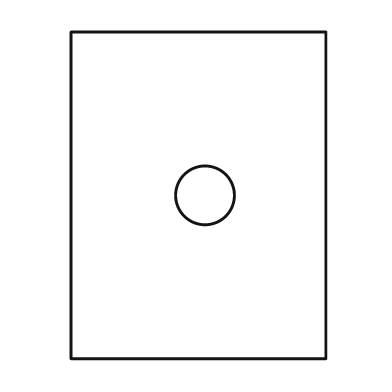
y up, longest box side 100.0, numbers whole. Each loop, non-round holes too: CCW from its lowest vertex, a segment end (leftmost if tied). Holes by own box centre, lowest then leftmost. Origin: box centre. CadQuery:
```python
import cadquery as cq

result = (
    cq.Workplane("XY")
    .moveTo(-39.0, -50.0)
    .lineTo(39.0, -50.0)
    .lineTo(39.0, 50.0)
    .lineTo(-39.0, 50.0)
    .close()
    .moveTo(2.0, 0.0)
    .circle(9.0)
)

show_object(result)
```